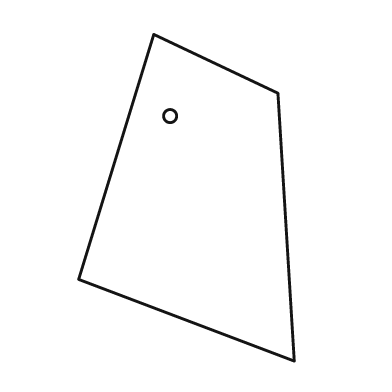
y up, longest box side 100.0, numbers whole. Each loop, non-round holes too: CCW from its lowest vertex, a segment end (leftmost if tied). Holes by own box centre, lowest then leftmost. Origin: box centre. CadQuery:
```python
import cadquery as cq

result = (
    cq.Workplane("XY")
    .moveTo(33.0, -50.0)
    .lineTo(28.0, 32.0)
    .lineTo(-10.0, 50.0)
    .lineTo(-33.0, -25.0)
    .close()
    .moveTo(-5.0, 25.0)
    .circle(2.0)
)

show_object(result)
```